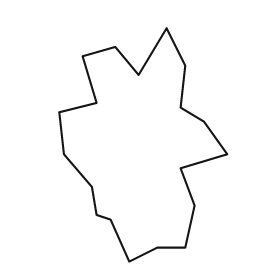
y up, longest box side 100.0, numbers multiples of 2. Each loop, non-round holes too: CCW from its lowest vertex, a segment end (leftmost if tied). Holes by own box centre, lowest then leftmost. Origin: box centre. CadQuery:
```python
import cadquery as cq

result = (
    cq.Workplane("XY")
    .moveTo(-6.0, -50.0)
    .lineTo(6.0, -44.0)
    .lineTo(18.0, -44.0)
    .lineTo(22.0, -26.0)
    .lineTo(16.0, -10.0)
    .lineTo(36.0, -4.0)
    .lineTo(26.0, 10.0)
    .lineTo(16.0, 16.0)
    .lineTo(18.0, 34.0)
    .lineTo(10.0, 50.0)
    .lineTo(-2.0, 30.0)
    .lineTo(-12.0, 42.0)
    .lineTo(-26.0, 38.0)
    .lineTo(-20.0, 18.0)
    .lineTo(-36.0, 14.0)
    .lineTo(-34.0, -4.0)
    .lineTo(-22.0, -18.0)
    .lineTo(-20.0, -30.0)
    .lineTo(-14.0, -32.0)
    .close()
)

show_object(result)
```